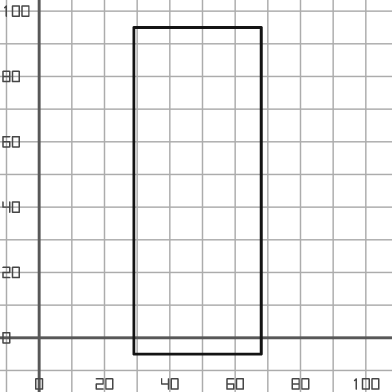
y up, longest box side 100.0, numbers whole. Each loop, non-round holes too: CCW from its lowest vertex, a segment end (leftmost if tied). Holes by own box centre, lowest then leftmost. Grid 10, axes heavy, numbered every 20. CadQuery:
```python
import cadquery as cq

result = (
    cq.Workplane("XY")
    .moveTo(29.0, -5.0)
    .lineTo(68.0, -5.0)
    .lineTo(68.0, 95.0)
    .lineTo(29.0, 95.0)
    .close()
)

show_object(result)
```